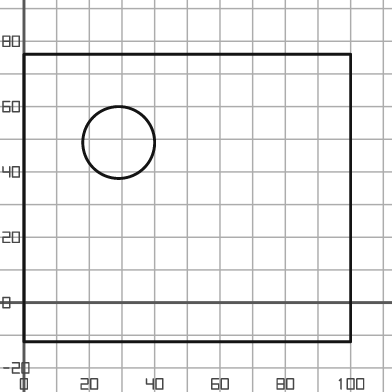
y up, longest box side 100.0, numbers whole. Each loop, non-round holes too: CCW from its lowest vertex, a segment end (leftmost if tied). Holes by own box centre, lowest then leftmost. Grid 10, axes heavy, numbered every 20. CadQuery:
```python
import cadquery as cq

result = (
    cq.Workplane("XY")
    .moveTo(0.0, -12.0)
    .lineTo(100.0, -12.0)
    .lineTo(100.0, 76.0)
    .lineTo(0.0, 76.0)
    .close()
    .moveTo(29.0, 49.0)
    .circle(11.0)
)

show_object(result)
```